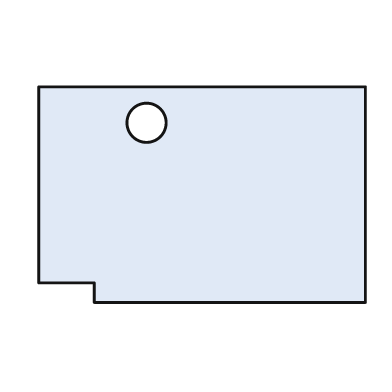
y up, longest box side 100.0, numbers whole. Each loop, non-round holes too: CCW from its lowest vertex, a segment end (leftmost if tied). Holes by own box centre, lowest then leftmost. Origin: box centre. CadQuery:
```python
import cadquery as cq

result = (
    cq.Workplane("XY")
    .moveTo(-33.0, -33.0)
    .lineTo(50.0, -33.0)
    .lineTo(50.0, 33.0)
    .lineTo(-50.0, 33.0)
    .lineTo(-50.0, -27.0)
    .lineTo(-33.0, -27.0)
    .close()
    .moveTo(-17.0, 22.0)
    .circle(6.0)
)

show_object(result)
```